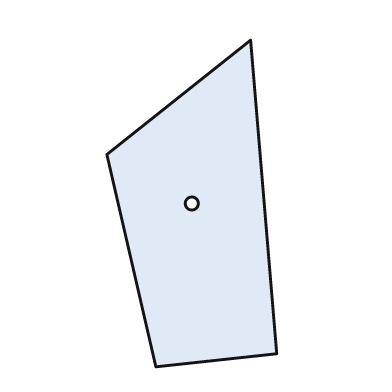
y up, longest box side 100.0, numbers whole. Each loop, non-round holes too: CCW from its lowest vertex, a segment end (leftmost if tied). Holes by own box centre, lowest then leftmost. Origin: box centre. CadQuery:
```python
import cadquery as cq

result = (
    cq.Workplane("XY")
    .moveTo(-11.0, -50.0)
    .lineTo(26.0, -46.0)
    .lineTo(18.0, 50.0)
    .lineTo(-26.0, 15.0)
    .close()
    .moveTo(0.0, 0.0)
    .circle(2.0)
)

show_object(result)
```